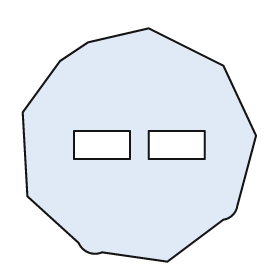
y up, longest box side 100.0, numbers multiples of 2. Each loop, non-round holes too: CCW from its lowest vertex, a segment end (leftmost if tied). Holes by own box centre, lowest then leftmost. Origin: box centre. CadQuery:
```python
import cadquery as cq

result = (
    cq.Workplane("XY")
    .moveTo(12.0, -50.0)
    .lineTo(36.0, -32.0)
    .threePointArc((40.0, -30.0), (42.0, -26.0))
    .lineTo(50.0, 4.0)
    .lineTo(36.0, 34.0)
    .lineTo(4.0, 50.0)
    .lineTo(-22.0, 44.0)
    .lineTo(-34.0, 36.0)
    .lineTo(-50.0, 14.0)
    .lineTo(-48.0, -22.0)
    .lineTo(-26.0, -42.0)
    .threePointArc((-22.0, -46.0), (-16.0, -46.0))
    .close()
    .moveTo(-28.0, -6.0)
    .lineTo(-4.0, -6.0)
    .lineTo(-4.0, 6.0)
    .lineTo(-28.0, 6.0)
    .close()
    .moveTo(4.0, -6.0)
    .lineTo(28.0, -6.0)
    .lineTo(28.0, 6.0)
    .lineTo(4.0, 6.0)
    .close()
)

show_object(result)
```